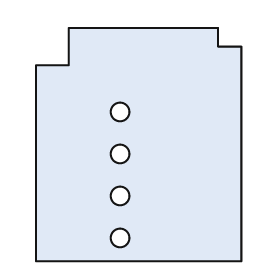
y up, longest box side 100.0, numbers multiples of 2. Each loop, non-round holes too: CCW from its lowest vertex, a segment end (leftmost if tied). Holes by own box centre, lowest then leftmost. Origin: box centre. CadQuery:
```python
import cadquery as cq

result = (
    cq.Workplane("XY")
    .moveTo(-44.0, -50.0)
    .lineTo(44.0, -50.0)
    .lineTo(44.0, 42.0)
    .lineTo(34.0, 42.0)
    .lineTo(34.0, 50.0)
    .lineTo(-30.0, 50.0)
    .lineTo(-30.0, 34.0)
    .lineTo(-44.0, 34.0)
    .close()
    .moveTo(-8.0, -40.0)
    .circle(4.0)
    .moveTo(-8.0, -22.0)
    .circle(4.0)
    .moveTo(-8.0, -4.0)
    .circle(4.0)
    .moveTo(-8.0, 14.0)
    .circle(4.0)
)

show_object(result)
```